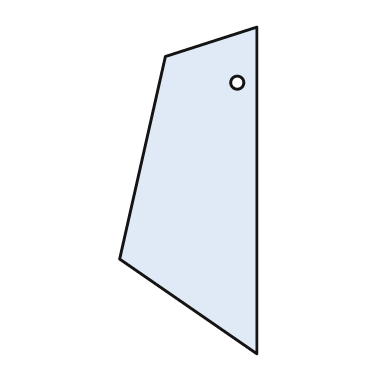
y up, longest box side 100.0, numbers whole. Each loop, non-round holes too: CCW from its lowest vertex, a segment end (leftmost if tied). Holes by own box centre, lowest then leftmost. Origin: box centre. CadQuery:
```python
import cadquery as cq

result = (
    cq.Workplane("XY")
    .moveTo(21.0, -50.0)
    .lineTo(21.0, 50.0)
    .lineTo(-7.0, 41.0)
    .lineTo(-21.0, -21.0)
    .close()
    .moveTo(15.0, 33.0)
    .circle(2.0)
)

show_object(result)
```